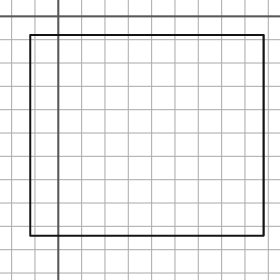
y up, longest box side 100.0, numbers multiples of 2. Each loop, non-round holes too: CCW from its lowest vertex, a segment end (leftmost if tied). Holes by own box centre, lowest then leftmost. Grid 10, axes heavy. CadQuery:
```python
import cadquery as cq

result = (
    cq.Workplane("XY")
    .moveTo(-12.0, -94.0)
    .lineTo(88.0, -94.0)
    .lineTo(88.0, -8.0)
    .lineTo(-12.0, -8.0)
    .close()
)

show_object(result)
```